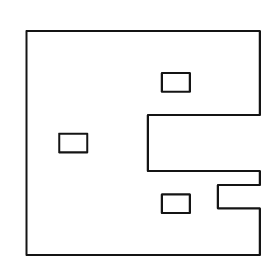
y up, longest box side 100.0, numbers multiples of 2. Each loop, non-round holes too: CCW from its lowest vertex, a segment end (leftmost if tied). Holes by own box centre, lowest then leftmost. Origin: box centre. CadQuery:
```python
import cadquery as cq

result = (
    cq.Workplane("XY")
    .moveTo(-50.0, -48.0)
    .lineTo(50.0, -48.0)
    .lineTo(50.0, -28.0)
    .lineTo(32.0, -28.0)
    .lineTo(32.0, -18.0)
    .lineTo(50.0, -18.0)
    .lineTo(50.0, -12.0)
    .lineTo(2.0, -12.0)
    .lineTo(2.0, 12.0)
    .lineTo(50.0, 12.0)
    .lineTo(50.0, 48.0)
    .lineTo(-50.0, 48.0)
    .close()
    .moveTo(8.0, -30.0)
    .lineTo(20.0, -30.0)
    .lineTo(20.0, -22.0)
    .lineTo(8.0, -22.0)
    .close()
    .moveTo(-36.0, -4.0)
    .lineTo(-24.0, -4.0)
    .lineTo(-24.0, 4.0)
    .lineTo(-36.0, 4.0)
    .close()
    .moveTo(8.0, 22.0)
    .lineTo(20.0, 22.0)
    .lineTo(20.0, 30.0)
    .lineTo(8.0, 30.0)
    .close()
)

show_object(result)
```